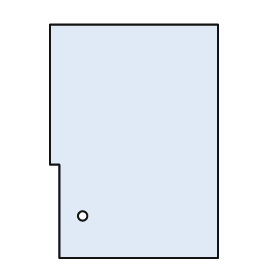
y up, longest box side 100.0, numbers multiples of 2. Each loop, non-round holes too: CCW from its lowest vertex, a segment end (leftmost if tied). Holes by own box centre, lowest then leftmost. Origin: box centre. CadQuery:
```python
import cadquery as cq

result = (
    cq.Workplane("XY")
    .moveTo(-32.0, -50.0)
    .lineTo(36.0, -50.0)
    .lineTo(36.0, 50.0)
    .lineTo(-36.0, 50.0)
    .lineTo(-36.0, -10.0)
    .lineTo(-32.0, -10.0)
    .close()
    .moveTo(-22.0, -32.0)
    .circle(2.0)
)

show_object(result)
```